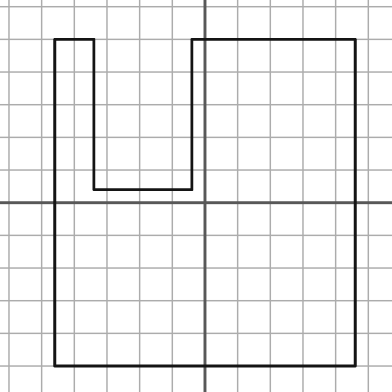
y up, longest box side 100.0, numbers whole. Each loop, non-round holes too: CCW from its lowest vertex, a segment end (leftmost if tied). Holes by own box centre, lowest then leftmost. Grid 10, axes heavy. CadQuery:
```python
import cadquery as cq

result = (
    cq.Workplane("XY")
    .moveTo(-46.0, -50.0)
    .lineTo(46.0, -50.0)
    .lineTo(46.0, 50.0)
    .lineTo(-4.0, 50.0)
    .lineTo(-4.0, 4.0)
    .lineTo(-34.0, 4.0)
    .lineTo(-34.0, 50.0)
    .lineTo(-46.0, 50.0)
    .close()
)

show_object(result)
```